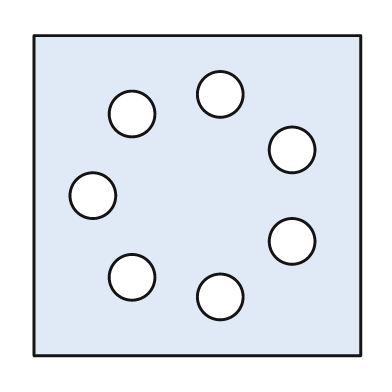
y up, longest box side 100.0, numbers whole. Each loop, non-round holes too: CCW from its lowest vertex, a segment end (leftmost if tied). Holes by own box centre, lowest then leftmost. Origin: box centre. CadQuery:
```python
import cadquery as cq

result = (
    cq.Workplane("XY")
    .moveTo(-50.0, -49.0)
    .lineTo(50.0, -49.0)
    .lineTo(50.0, 49.0)
    .lineTo(-50.0, 49.0)
    .close()
    .moveTo(7.0, -31.0)
    .circle(7.0)
    .moveTo(-20.0, -25.0)
    .circle(7.0)
    .moveTo(29.0, -14.0)
    .circle(7.0)
    .moveTo(-32.0, 0.0)
    .circle(7.0)
    .moveTo(29.0, 14.0)
    .circle(7.0)
    .moveTo(-20.0, 25.0)
    .circle(7.0)
    .moveTo(7.0, 31.0)
    .circle(7.0)
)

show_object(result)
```